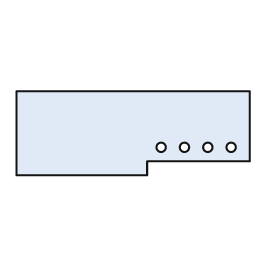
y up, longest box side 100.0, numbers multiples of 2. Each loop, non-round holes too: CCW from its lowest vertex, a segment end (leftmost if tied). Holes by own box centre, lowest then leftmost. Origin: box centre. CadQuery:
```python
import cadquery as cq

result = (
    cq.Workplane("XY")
    .moveTo(-50.0, -18.0)
    .lineTo(6.0, -18.0)
    .lineTo(6.0, -12.0)
    .lineTo(50.0, -12.0)
    .lineTo(50.0, 18.0)
    .lineTo(-50.0, 18.0)
    .close()
    .moveTo(12.0, -6.0)
    .circle(2.0)
    .moveTo(22.0, -6.0)
    .circle(2.0)
    .moveTo(32.0, -6.0)
    .circle(2.0)
    .moveTo(42.0, -6.0)
    .circle(2.0)
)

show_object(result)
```